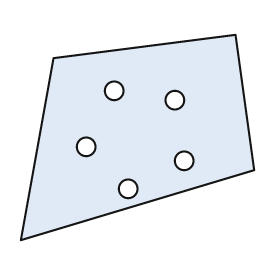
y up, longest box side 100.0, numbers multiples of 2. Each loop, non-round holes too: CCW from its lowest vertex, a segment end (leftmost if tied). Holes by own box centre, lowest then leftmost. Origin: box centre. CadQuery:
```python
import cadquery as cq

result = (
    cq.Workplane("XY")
    .moveTo(-50.0, -44.0)
    .lineTo(50.0, -14.0)
    .lineTo(42.0, 44.0)
    .lineTo(-36.0, 34.0)
    .close()
    .moveTo(-4.0, -22.0)
    .circle(4.0)
    .moveTo(20.0, -10.0)
    .circle(4.0)
    .moveTo(-22.0, -4.0)
    .circle(4.0)
    .moveTo(16.0, 16.0)
    .circle(4.0)
    .moveTo(-10.0, 20.0)
    .circle(4.0)
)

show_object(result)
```